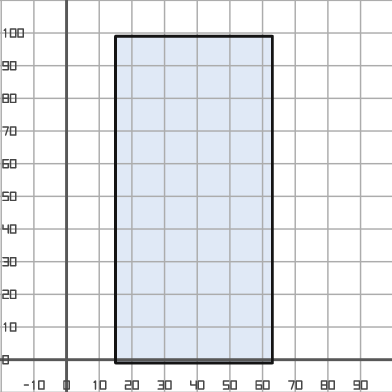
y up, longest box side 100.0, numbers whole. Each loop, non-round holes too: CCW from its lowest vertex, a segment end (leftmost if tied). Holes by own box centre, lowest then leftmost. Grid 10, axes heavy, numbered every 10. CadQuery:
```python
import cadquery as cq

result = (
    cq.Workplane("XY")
    .moveTo(15.0, -1.0)
    .lineTo(63.0, -1.0)
    .lineTo(63.0, 99.0)
    .lineTo(15.0, 99.0)
    .close()
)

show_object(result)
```